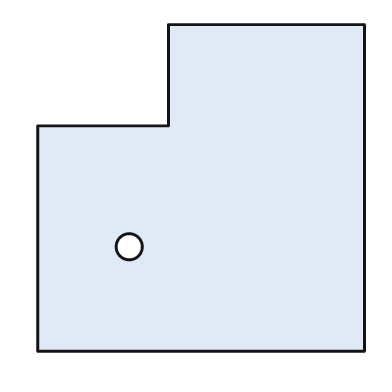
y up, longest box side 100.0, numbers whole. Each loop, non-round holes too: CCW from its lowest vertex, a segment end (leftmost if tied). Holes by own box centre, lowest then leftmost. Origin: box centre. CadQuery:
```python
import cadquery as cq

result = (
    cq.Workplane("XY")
    .moveTo(-50.0, -50.0)
    .lineTo(50.0, -50.0)
    .lineTo(50.0, 50.0)
    .lineTo(-10.0, 50.0)
    .lineTo(-10.0, 19.0)
    .lineTo(-50.0, 19.0)
    .close()
    .moveTo(-22.0, -18.0)
    .circle(4.0)
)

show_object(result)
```